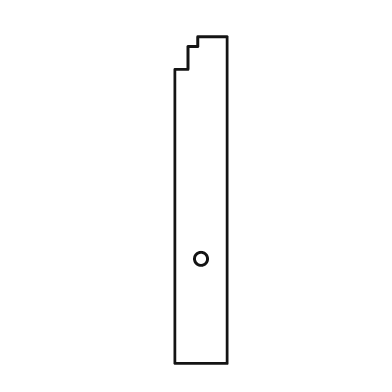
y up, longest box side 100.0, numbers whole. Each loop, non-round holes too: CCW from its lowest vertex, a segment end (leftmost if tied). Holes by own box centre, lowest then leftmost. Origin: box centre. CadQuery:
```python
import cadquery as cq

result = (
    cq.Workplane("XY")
    .moveTo(-8.0, -50.0)
    .lineTo(8.0, -50.0)
    .lineTo(8.0, 50.0)
    .lineTo(-1.0, 50.0)
    .lineTo(-1.0, 47.0)
    .lineTo(-4.0, 47.0)
    .lineTo(-4.0, 40.0)
    .lineTo(-8.0, 40.0)
    .close()
    .moveTo(0.0, -18.0)
    .circle(2.0)
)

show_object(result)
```